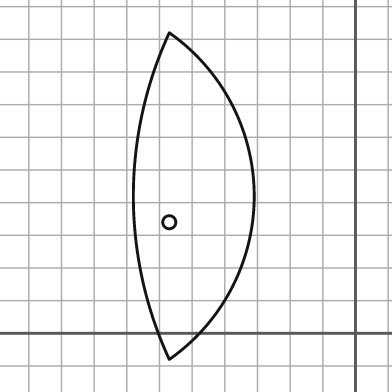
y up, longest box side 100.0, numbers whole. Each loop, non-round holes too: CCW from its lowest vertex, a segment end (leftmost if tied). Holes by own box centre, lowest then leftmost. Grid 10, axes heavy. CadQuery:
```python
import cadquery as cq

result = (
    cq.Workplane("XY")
    .moveTo(-57.0, -8.0)
    .threePointArc((-31.0, 42.0), (-57.0, 92.0))
    .threePointArc((-68.0, 42.0), (-57.0, -8.0))
    .close()
    .moveTo(-57.0, 34.0)
    .circle(2.0)
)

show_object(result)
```